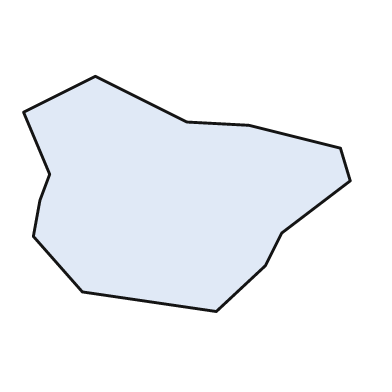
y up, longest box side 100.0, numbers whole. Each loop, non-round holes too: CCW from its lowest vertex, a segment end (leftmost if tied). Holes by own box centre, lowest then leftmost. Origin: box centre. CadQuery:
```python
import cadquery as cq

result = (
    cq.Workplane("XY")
    .moveTo(9.0, -36.0)
    .lineTo(24.0, -22.0)
    .lineTo(29.0, -12.0)
    .lineTo(50.0, 4.0)
    .lineTo(47.0, 14.0)
    .lineTo(19.0, 21.0)
    .lineTo(0.0, 22.0)
    .lineTo(-28.0, 36.0)
    .lineTo(-50.0, 25.0)
    .lineTo(-42.0, 6.0)
    .lineTo(-45.0, -2.0)
    .lineTo(-47.0, -13.0)
    .lineTo(-32.0, -30.0)
    .close()
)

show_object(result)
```